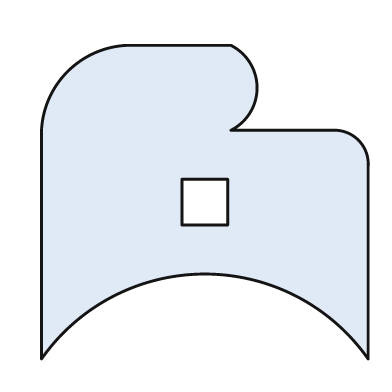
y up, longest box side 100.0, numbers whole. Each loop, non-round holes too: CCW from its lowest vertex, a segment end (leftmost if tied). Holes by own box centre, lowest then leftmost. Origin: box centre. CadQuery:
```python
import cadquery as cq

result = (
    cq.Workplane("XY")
    .moveTo(-50.0, -48.0)
    .threePointArc((0.0, -22.0), (50.0, -48.0))
    .lineTo(50.0, 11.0)
    .threePointArc((47.0, 19.0), (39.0, 22.0))
    .lineTo(8.0, 22.0)
    .threePointArc((16.0, 35.0), (8.0, 48.0))
    .lineTo(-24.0, 48.0)
    .threePointArc((-42.0, 40.0), (-50.0, 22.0))
    .close()
    .moveTo(-7.0, -7.0)
    .lineTo(7.0, -7.0)
    .lineTo(7.0, 7.0)
    .lineTo(-7.0, 7.0)
    .close()
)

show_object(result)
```